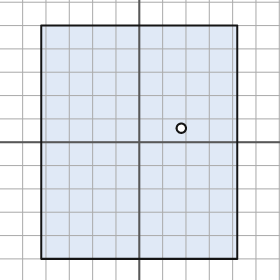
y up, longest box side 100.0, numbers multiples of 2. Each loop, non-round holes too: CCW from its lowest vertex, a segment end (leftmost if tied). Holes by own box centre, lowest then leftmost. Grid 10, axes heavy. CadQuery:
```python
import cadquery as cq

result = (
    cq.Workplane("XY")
    .moveTo(-42.0, -50.0)
    .lineTo(42.0, -50.0)
    .lineTo(42.0, 50.0)
    .lineTo(-42.0, 50.0)
    .close()
    .moveTo(18.0, 6.0)
    .circle(2.0)
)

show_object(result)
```